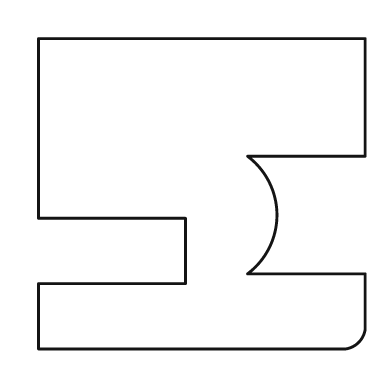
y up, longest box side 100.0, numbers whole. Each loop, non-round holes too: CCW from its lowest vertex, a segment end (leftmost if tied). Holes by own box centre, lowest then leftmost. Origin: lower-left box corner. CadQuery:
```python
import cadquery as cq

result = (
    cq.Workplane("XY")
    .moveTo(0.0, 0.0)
    .lineTo(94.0, 0.0)
    .threePointArc((98.0, 2.0), (100.0, 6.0))
    .lineTo(100.0, 23.0)
    .lineTo(64.0, 23.0)
    .threePointArc((73.0, 41.0), (64.0, 59.0))
    .lineTo(100.0, 59.0)
    .lineTo(100.0, 95.0)
    .lineTo(0.0, 95.0)
    .lineTo(0.0, 40.0)
    .lineTo(45.0, 40.0)
    .lineTo(45.0, 20.0)
    .lineTo(0.0, 20.0)
    .close()
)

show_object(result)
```